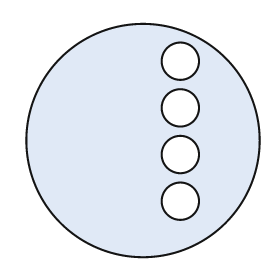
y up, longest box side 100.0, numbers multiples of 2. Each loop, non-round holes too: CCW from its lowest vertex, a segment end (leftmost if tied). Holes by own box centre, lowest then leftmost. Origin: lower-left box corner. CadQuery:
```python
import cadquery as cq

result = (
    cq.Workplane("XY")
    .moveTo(50.0, 50.0)
    .circle(50.0)
    .moveTo(66.0, 24.0)
    .circle(8.0)
    .moveTo(66.0, 44.0)
    .circle(8.0)
    .moveTo(66.0, 64.0)
    .circle(8.0)
    .moveTo(66.0, 84.0)
    .circle(8.0)
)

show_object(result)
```